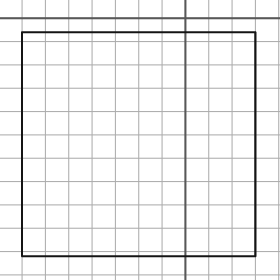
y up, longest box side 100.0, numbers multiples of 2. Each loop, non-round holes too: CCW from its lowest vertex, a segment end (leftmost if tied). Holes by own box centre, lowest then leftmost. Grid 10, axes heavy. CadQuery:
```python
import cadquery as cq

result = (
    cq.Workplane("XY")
    .moveTo(-70.0, -102.0)
    .lineTo(30.0, -102.0)
    .lineTo(30.0, -6.0)
    .lineTo(-70.0, -6.0)
    .close()
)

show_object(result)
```